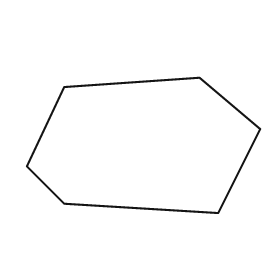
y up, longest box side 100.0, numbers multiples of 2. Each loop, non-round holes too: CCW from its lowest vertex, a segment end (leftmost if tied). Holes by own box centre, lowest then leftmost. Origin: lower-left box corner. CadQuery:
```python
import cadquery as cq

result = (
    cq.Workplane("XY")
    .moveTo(82.0, 0.0)
    .lineTo(100.0, 36.0)
    .lineTo(74.0, 58.0)
    .lineTo(16.0, 54.0)
    .lineTo(0.0, 20.0)
    .lineTo(16.0, 4.0)
    .close()
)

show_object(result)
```